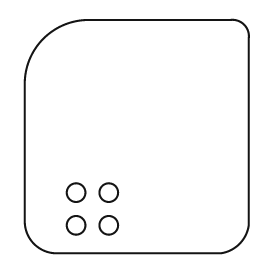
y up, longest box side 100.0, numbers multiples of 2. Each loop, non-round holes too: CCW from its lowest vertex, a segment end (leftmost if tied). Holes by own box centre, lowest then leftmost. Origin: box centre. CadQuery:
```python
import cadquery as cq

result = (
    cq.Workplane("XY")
    .moveTo(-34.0, -50.0)
    .lineTo(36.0, -50.0)
    .threePointArc((44.0, -46.0), (48.0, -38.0))
    .lineTo(48.0, 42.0)
    .threePointArc((46.0, 48.0), (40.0, 50.0))
    .lineTo(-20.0, 50.0)
    .threePointArc((-40.0, 42.0), (-48.0, 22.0))
    .lineTo(-48.0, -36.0)
    .threePointArc((-44.0, -46.0), (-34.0, -50.0))
    .close()
    .moveTo(-26.0, -38.0)
    .circle(4.0)
    .moveTo(-12.0, -38.0)
    .circle(4.0)
    .moveTo(-26.0, -24.0)
    .circle(4.0)
    .moveTo(-12.0, -24.0)
    .circle(4.0)
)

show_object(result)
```